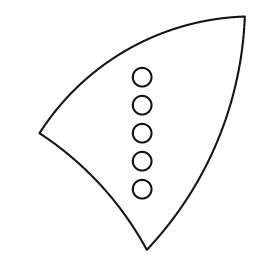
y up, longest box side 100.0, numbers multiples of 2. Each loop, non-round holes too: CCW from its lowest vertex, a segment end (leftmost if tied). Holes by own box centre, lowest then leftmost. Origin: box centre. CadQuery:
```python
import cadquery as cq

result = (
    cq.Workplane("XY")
    .moveTo(2.0, -50.0)
    .threePointArc((32.0, -4.0), (44.0, 50.0))
    .threePointArc((-6.0, 36.0), (-44.0, 0.0))
    .threePointArc((-18.0, -22.0), (2.0, -50.0))
    .close()
    .moveTo(0.0, -24.0)
    .circle(4.0)
    .moveTo(0.0, -12.0)
    .circle(4.0)
    .moveTo(0.0, 0.0)
    .circle(4.0)
    .moveTo(0.0, 12.0)
    .circle(4.0)
    .moveTo(0.0, 24.0)
    .circle(4.0)
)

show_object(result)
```